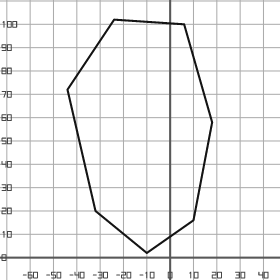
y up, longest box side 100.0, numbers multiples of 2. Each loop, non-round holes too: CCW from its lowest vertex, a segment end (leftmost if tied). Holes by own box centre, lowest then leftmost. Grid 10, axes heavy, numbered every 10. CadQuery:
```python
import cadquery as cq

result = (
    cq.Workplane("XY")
    .moveTo(-10.0, 2.0)
    .lineTo(10.0, 16.0)
    .lineTo(18.0, 58.0)
    .lineTo(6.0, 100.0)
    .lineTo(-24.0, 102.0)
    .lineTo(-44.0, 72.0)
    .lineTo(-32.0, 20.0)
    .close()
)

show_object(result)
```